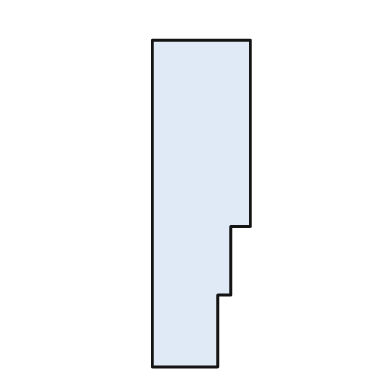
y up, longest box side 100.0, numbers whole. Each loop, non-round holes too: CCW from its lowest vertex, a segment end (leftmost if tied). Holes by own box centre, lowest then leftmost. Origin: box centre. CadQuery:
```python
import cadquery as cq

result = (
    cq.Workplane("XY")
    .moveTo(-15.0, -50.0)
    .lineTo(5.0, -50.0)
    .lineTo(5.0, -28.0)
    .lineTo(9.0, -28.0)
    .lineTo(9.0, -7.0)
    .lineTo(15.0, -7.0)
    .lineTo(15.0, 50.0)
    .lineTo(-15.0, 50.0)
    .close()
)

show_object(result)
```